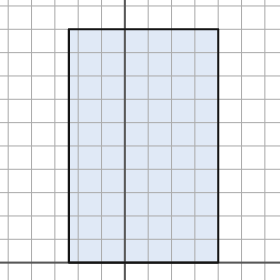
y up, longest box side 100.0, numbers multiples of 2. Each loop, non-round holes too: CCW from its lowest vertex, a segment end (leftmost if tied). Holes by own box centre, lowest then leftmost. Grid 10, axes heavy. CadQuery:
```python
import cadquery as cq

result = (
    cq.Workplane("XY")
    .moveTo(-24.0, 0.0)
    .lineTo(40.0, 0.0)
    .lineTo(40.0, 100.0)
    .lineTo(-24.0, 100.0)
    .close()
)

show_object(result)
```